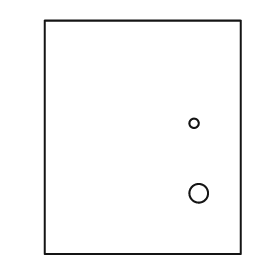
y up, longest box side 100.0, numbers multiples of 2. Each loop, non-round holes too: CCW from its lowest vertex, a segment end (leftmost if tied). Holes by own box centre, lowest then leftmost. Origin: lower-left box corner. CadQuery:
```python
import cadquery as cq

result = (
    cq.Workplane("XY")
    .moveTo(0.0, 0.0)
    .lineTo(84.0, 0.0)
    .lineTo(84.0, 100.0)
    .lineTo(0.0, 100.0)
    .close()
    .moveTo(66.0, 26.0)
    .circle(4.0)
    .moveTo(64.0, 56.0)
    .circle(2.0)
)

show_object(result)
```